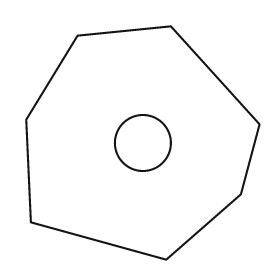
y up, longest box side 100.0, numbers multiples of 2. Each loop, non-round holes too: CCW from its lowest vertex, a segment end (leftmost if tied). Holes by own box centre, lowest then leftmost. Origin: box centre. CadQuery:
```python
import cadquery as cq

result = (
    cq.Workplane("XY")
    .moveTo(10.0, -50.0)
    .lineTo(42.0, -22.0)
    .lineTo(50.0, 8.0)
    .lineTo(12.0, 50.0)
    .lineTo(-28.0, 46.0)
    .lineTo(-50.0, 10.0)
    .lineTo(-48.0, -34.0)
    .close()
    .moveTo(0.0, 0.0)
    .circle(12.0)
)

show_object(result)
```